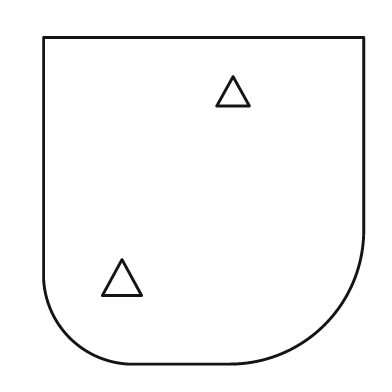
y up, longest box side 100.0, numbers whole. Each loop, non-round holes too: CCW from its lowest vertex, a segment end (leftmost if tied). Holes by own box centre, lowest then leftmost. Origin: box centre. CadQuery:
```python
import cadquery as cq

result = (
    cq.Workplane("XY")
    .moveTo(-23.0, -50.0)
    .lineTo(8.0, -50.0)
    .threePointArc((37.0, -38.0), (49.0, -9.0))
    .lineTo(49.0, 50.0)
    .lineTo(-49.0, 50.0)
    .lineTo(-49.0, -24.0)
    .threePointArc((-41.0, -42.0), (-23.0, -50.0))
    .close()
    .moveTo(-31.0, -29.0)
    .lineTo(-19.0, -29.0)
    .lineTo(-25.0, -18.0)
    .close()
    .moveTo(4.0, 29.0)
    .lineTo(14.0, 29.0)
    .lineTo(9.0, 38.0)
    .close()
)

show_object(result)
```